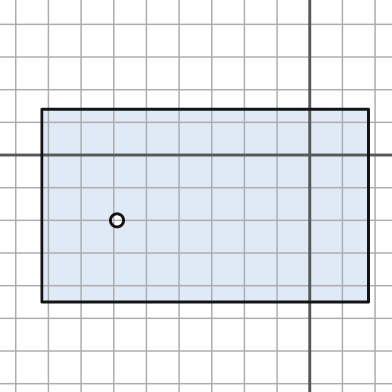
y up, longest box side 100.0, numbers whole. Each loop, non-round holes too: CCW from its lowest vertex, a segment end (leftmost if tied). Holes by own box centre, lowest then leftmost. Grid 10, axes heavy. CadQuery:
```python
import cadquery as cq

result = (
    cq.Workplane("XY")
    .moveTo(-82.0, -45.0)
    .lineTo(18.0, -45.0)
    .lineTo(18.0, 14.0)
    .lineTo(-82.0, 14.0)
    .close()
    .moveTo(-59.0, -20.0)
    .circle(2.0)
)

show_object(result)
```